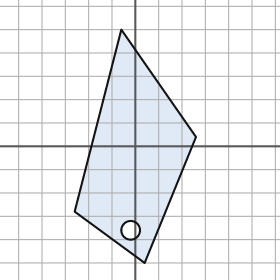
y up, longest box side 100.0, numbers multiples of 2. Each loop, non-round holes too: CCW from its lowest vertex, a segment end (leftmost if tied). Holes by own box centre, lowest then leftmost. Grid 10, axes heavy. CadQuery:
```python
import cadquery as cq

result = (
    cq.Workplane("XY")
    .moveTo(4.0, -50.0)
    .lineTo(26.0, 4.0)
    .lineTo(-6.0, 50.0)
    .lineTo(-26.0, -28.0)
    .close()
    .moveTo(-2.0, -36.0)
    .circle(4.0)
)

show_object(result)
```